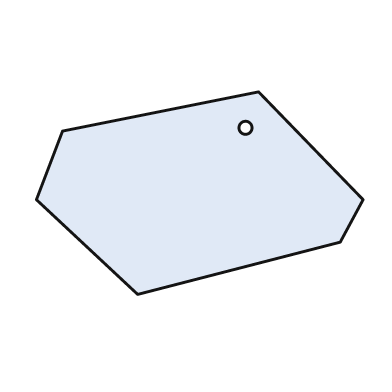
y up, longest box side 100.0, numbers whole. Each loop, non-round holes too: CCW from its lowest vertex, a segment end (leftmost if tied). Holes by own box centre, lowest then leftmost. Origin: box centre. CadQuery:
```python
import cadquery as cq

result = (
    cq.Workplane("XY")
    .moveTo(-19.0, -31.0)
    .lineTo(43.0, -15.0)
    .lineTo(50.0, -2.0)
    .lineTo(18.0, 31.0)
    .lineTo(-42.0, 19.0)
    .lineTo(-50.0, -2.0)
    .close()
    .moveTo(14.0, 20.0)
    .circle(2.0)
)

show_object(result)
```